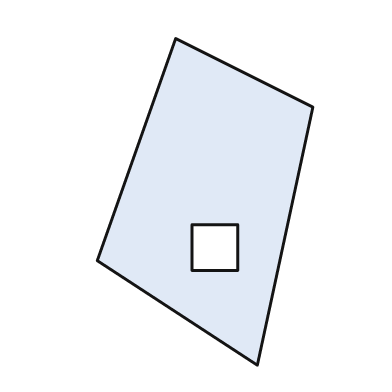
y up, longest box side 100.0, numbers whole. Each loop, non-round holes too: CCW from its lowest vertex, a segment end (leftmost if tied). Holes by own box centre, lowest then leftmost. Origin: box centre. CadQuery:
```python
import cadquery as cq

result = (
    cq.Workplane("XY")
    .moveTo(16.0, -50.0)
    .lineTo(33.0, 29.0)
    .lineTo(-9.0, 50.0)
    .lineTo(-33.0, -18.0)
    .close()
    .moveTo(-4.0, -21.0)
    .lineTo(10.0, -21.0)
    .lineTo(10.0, -7.0)
    .lineTo(-4.0, -7.0)
    .close()
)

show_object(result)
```